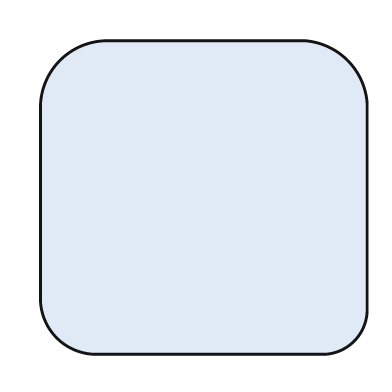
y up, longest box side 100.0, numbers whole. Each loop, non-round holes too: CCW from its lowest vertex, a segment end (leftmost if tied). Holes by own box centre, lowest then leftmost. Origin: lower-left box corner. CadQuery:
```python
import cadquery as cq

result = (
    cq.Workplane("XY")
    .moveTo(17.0, 0.0)
    .lineTo(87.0, 0.0)
    .threePointArc((96.0, 4.0), (100.0, 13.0))
    .lineTo(100.0, 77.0)
    .threePointArc((94.0, 90.0), (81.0, 96.0))
    .lineTo(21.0, 96.0)
    .threePointArc((6.0, 90.0), (0.0, 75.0))
    .lineTo(0.0, 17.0)
    .threePointArc((5.0, 5.0), (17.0, 0.0))
    .close()
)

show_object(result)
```